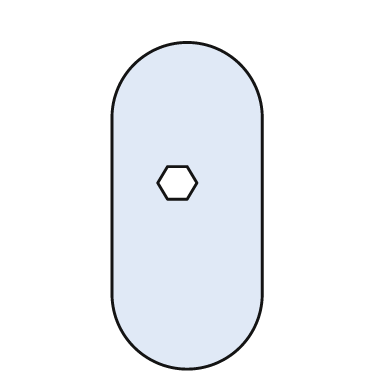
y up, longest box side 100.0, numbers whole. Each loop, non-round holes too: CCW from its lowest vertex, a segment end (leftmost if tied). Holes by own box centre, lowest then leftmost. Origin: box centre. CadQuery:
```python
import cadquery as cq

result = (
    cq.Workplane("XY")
    .moveTo(-23.0, -27.0)
    .threePointArc((0.0, -50.0), (23.0, -27.0))
    .lineTo(23.0, 27.0)
    .threePointArc((0.0, 50.0), (-23.0, 27.0))
    .close()
    .moveTo(-6.0, 2.0)
    .lineTo(0.0, 2.0)
    .lineTo(3.0, 7.0)
    .lineTo(0.0, 12.0)
    .lineTo(-6.0, 12.0)
    .lineTo(-9.0, 7.0)
    .close()
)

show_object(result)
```